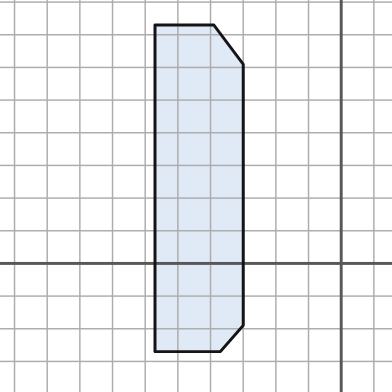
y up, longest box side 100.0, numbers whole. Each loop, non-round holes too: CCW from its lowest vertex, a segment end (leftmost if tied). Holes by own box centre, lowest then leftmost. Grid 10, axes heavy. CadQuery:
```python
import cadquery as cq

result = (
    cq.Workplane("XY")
    .moveTo(-57.0, -27.0)
    .lineTo(-37.0, -27.0)
    .lineTo(-30.0, -19.0)
    .lineTo(-30.0, 61.0)
    .lineTo(-39.0, 73.0)
    .lineTo(-57.0, 73.0)
    .close()
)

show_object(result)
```